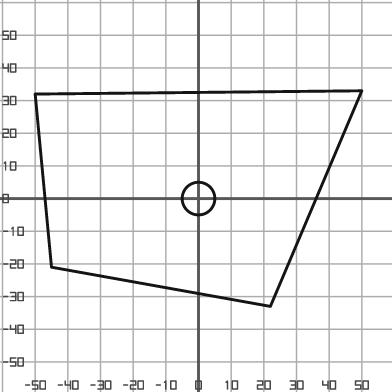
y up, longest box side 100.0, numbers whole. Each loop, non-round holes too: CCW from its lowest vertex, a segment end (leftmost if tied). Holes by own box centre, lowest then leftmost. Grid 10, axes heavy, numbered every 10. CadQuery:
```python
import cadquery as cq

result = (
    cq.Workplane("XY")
    .moveTo(22.0, -33.0)
    .lineTo(50.0, 33.0)
    .lineTo(-50.0, 32.0)
    .lineTo(-45.0, -21.0)
    .close()
    .moveTo(0.0, 0.0)
    .circle(5.0)
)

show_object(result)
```